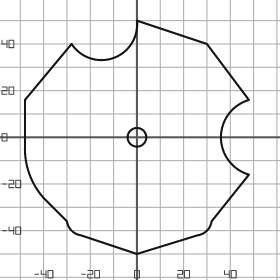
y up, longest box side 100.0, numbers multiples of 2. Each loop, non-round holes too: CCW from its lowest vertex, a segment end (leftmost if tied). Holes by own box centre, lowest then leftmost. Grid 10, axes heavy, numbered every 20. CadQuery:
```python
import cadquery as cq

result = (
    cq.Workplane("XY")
    .moveTo(0.0, -50.0)
    .lineTo(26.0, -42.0)
    .threePointArc((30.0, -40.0), (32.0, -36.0))
    .lineTo(48.0, -16.0)
    .threePointArc((36.0, 0.0), (48.0, 16.0))
    .lineTo(30.0, 40.0)
    .lineTo(0.0, 50.0)
    .threePointArc((-10.0, 34.0), (-28.0, 40.0))
    .lineTo(-48.0, 16.0)
    .lineTo(-48.0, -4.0)
    .threePointArc((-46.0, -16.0), (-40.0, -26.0))
    .lineTo(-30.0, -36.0)
    .threePointArc((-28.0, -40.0), (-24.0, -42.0))
    .close()
    .moveTo(0.0, 0.0)
    .circle(4.0)
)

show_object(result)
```